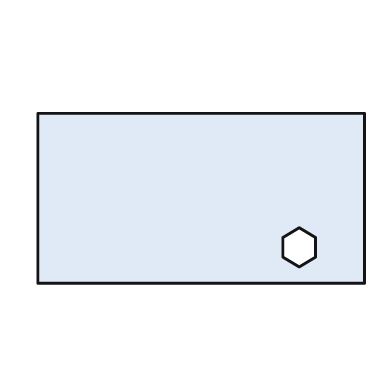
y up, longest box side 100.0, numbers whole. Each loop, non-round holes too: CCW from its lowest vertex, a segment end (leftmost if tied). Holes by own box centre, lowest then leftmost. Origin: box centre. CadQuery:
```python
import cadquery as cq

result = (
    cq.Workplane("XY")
    .moveTo(-50.0, -26.0)
    .lineTo(50.0, -26.0)
    .lineTo(50.0, 26.0)
    .lineTo(-50.0, 26.0)
    .close()
    .moveTo(30.0, -21.0)
    .lineTo(35.0, -18.0)
    .lineTo(35.0, -12.0)
    .lineTo(30.0, -9.0)
    .lineTo(25.0, -12.0)
    .lineTo(25.0, -18.0)
    .close()
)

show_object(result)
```